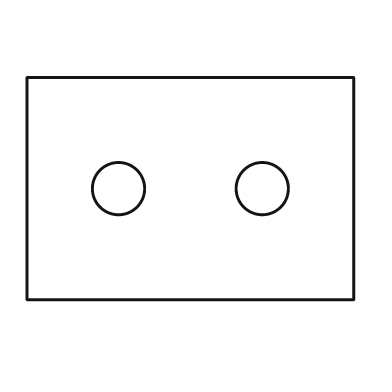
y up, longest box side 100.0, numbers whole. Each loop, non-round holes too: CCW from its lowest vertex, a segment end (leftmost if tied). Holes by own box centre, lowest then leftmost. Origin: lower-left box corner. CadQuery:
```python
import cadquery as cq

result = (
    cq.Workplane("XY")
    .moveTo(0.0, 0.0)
    .lineTo(100.0, 0.0)
    .lineTo(100.0, 68.0)
    .lineTo(0.0, 68.0)
    .close()
    .moveTo(28.0, 34.0)
    .circle(8.0)
    .moveTo(72.0, 34.0)
    .circle(8.0)
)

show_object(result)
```